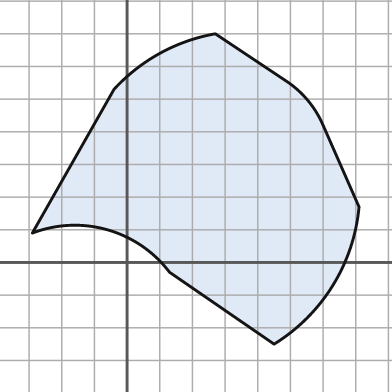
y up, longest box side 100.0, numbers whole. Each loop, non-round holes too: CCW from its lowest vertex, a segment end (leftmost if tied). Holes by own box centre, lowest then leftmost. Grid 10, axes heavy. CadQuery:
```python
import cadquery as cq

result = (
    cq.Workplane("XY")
    .moveTo(45.0, -25.0)
    .threePointArc((63.0, -7.0), (71.0, 17.0))
    .lineTo(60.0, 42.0)
    .threePointArc((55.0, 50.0), (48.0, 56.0))
    .lineTo(27.0, 70.0)
    .threePointArc((10.0, 64.0), (-4.0, 53.0))
    .lineTo(-29.0, 9.0)
    .threePointArc((-6.0, 10.0), (13.0, -3.0))
    .close()
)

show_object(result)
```